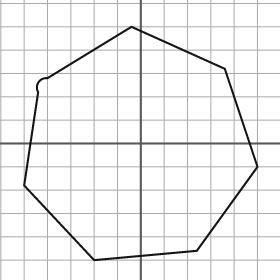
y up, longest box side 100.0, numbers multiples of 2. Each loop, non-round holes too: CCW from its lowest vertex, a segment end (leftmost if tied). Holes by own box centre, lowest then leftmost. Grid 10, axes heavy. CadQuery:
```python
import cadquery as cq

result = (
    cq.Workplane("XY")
    .moveTo(-20.0, -50.0)
    .lineTo(24.0, -46.0)
    .lineTo(50.0, -10.0)
    .lineTo(36.0, 32.0)
    .lineTo(-4.0, 50.0)
    .lineTo(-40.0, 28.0)
    .threePointArc((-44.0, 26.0), (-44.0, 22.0))
    .lineTo(-50.0, -18.0)
    .close()
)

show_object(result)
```